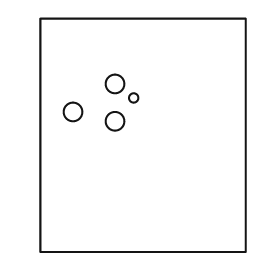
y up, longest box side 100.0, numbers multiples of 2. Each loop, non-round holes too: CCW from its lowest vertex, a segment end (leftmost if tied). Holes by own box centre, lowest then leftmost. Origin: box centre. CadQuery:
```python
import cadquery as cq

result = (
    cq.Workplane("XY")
    .moveTo(-44.0, -50.0)
    .lineTo(44.0, -50.0)
    .lineTo(44.0, 50.0)
    .lineTo(-44.0, 50.0)
    .close()
    .moveTo(-12.0, 6.0)
    .circle(4.0)
    .moveTo(-30.0, 10.0)
    .circle(4.0)
    .moveTo(-4.0, 16.0)
    .circle(2.0)
    .moveTo(-12.0, 22.0)
    .circle(4.0)
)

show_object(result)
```